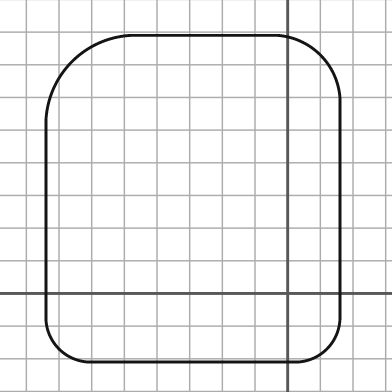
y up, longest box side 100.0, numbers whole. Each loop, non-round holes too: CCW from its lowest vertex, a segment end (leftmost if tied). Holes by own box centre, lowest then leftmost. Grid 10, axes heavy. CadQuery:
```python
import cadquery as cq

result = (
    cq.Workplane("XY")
    .moveTo(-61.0, -21.0)
    .lineTo(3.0, -21.0)
    .threePointArc((12.0, -17.0), (16.0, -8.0))
    .lineTo(16.0, 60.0)
    .threePointArc((10.0, 73.0), (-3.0, 79.0))
    .lineTo(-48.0, 79.0)
    .threePointArc((-66.0, 71.0), (-74.0, 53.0))
    .lineTo(-74.0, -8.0)
    .threePointArc((-70.0, -17.0), (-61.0, -21.0))
    .close()
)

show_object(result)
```